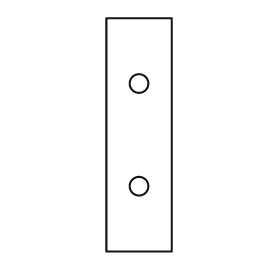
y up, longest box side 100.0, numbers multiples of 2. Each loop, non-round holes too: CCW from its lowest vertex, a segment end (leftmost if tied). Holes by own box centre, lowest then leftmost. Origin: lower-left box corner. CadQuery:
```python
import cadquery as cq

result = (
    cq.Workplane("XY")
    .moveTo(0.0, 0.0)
    .lineTo(28.0, 0.0)
    .lineTo(28.0, 100.0)
    .lineTo(0.0, 100.0)
    .close()
    .moveTo(14.0, 28.0)
    .circle(4.0)
    .moveTo(14.0, 72.0)
    .circle(4.0)
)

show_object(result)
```